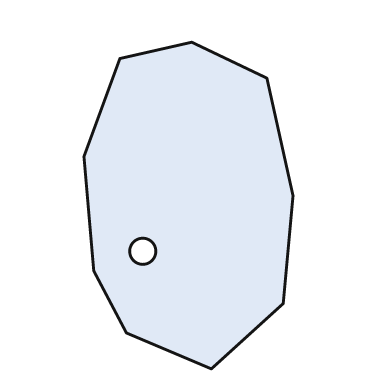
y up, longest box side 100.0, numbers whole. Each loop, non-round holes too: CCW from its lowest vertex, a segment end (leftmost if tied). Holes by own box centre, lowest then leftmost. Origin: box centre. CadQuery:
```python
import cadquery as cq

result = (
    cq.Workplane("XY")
    .moveTo(7.0, -50.0)
    .lineTo(29.0, -30.0)
    .lineTo(32.0, 3.0)
    .lineTo(24.0, 39.0)
    .lineTo(1.0, 50.0)
    .lineTo(-21.0, 45.0)
    .lineTo(-32.0, 15.0)
    .lineTo(-29.0, -20.0)
    .lineTo(-19.0, -39.0)
    .close()
    .moveTo(-14.0, -14.0)
    .circle(4.0)
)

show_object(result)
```